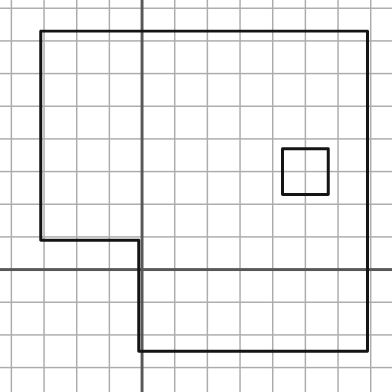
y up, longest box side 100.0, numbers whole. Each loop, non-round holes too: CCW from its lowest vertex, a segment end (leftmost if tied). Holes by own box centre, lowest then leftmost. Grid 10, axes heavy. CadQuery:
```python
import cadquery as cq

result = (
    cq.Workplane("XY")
    .moveTo(-1.0, -25.0)
    .lineTo(69.0, -25.0)
    .lineTo(69.0, 73.0)
    .lineTo(-31.0, 73.0)
    .lineTo(-31.0, 9.0)
    .lineTo(-1.0, 9.0)
    .close()
    .moveTo(43.0, 23.0)
    .lineTo(57.0, 23.0)
    .lineTo(57.0, 37.0)
    .lineTo(43.0, 37.0)
    .close()
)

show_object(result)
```